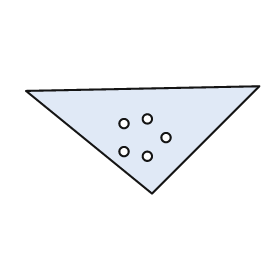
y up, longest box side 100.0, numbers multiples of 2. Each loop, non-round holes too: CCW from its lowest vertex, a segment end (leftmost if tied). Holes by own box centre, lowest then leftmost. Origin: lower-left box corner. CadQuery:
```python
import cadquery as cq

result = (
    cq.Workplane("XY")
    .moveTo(54.0, 0.0)
    .lineTo(100.0, 46.0)
    .lineTo(0.0, 44.0)
    .close()
    .moveTo(52.0, 16.0)
    .circle(2.0)
    .moveTo(42.0, 18.0)
    .circle(2.0)
    .moveTo(60.0, 24.0)
    .circle(2.0)
    .moveTo(42.0, 30.0)
    .circle(2.0)
    .moveTo(52.0, 32.0)
    .circle(2.0)
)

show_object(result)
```